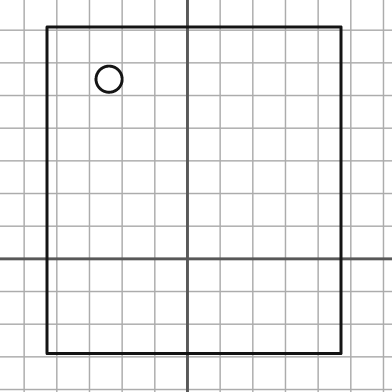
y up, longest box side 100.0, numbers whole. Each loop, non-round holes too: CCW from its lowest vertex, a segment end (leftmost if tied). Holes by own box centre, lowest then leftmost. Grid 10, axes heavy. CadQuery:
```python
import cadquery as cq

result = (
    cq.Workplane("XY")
    .moveTo(-43.0, -29.0)
    .lineTo(47.0, -29.0)
    .lineTo(47.0, 71.0)
    .lineTo(-43.0, 71.0)
    .close()
    .moveTo(-24.0, 55.0)
    .circle(4.0)
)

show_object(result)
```